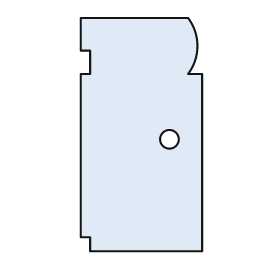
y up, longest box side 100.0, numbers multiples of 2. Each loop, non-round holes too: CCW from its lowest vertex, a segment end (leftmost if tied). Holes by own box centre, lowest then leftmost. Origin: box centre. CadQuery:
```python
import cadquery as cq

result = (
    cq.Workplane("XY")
    .moveTo(-22.0, -50.0)
    .lineTo(26.0, -50.0)
    .lineTo(26.0, 26.0)
    .lineTo(20.0, 26.0)
    .threePointArc((24.0, 38.0), (20.0, 50.0))
    .lineTo(-26.0, 50.0)
    .lineTo(-26.0, 36.0)
    .lineTo(-22.0, 36.0)
    .lineTo(-22.0, 26.0)
    .lineTo(-26.0, 26.0)
    .lineTo(-26.0, -44.0)
    .lineTo(-22.0, -44.0)
    .close()
    .moveTo(12.0, -2.0)
    .circle(4.0)
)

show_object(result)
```